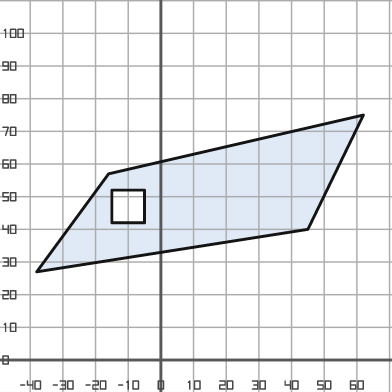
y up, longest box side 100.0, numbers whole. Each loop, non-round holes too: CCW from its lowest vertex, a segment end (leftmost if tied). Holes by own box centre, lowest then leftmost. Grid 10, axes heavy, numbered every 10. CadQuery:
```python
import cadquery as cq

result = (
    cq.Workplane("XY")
    .moveTo(-38.0, 27.0)
    .lineTo(45.0, 40.0)
    .lineTo(62.0, 75.0)
    .lineTo(-16.0, 57.0)
    .close()
    .moveTo(-15.0, 42.0)
    .lineTo(-5.0, 42.0)
    .lineTo(-5.0, 52.0)
    .lineTo(-15.0, 52.0)
    .close()
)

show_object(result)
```